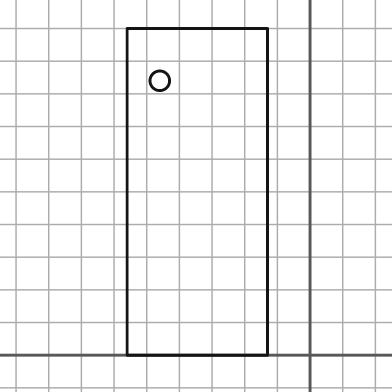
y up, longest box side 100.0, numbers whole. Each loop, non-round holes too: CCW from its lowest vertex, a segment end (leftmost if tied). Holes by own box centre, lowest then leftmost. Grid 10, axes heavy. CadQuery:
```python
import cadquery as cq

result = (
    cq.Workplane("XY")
    .moveTo(-56.0, 0.0)
    .lineTo(-13.0, 0.0)
    .lineTo(-13.0, 100.0)
    .lineTo(-56.0, 100.0)
    .close()
    .moveTo(-46.0, 84.0)
    .circle(3.0)
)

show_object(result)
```